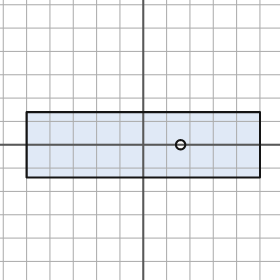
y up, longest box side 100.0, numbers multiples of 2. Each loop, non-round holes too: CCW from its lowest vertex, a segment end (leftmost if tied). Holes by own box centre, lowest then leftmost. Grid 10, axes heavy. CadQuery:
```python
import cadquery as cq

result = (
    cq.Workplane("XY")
    .moveTo(-50.0, -14.0)
    .lineTo(50.0, -14.0)
    .lineTo(50.0, 14.0)
    .lineTo(-50.0, 14.0)
    .close()
    .moveTo(16.0, 0.0)
    .circle(2.0)
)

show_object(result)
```